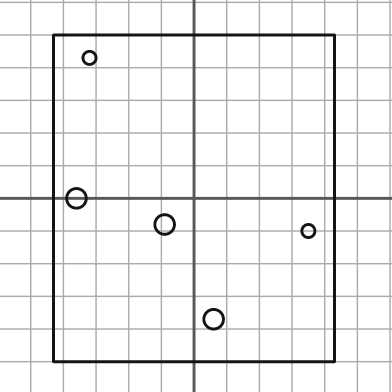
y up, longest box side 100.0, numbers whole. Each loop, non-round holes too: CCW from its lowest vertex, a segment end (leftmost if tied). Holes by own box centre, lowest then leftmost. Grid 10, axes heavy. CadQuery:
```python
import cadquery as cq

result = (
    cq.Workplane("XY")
    .moveTo(-43.0, -50.0)
    .lineTo(43.0, -50.0)
    .lineTo(43.0, 50.0)
    .lineTo(-43.0, 50.0)
    .close()
    .moveTo(6.0, -37.0)
    .circle(3.0)
    .moveTo(35.0, -10.0)
    .circle(2.0)
    .moveTo(-9.0, -8.0)
    .circle(3.0)
    .moveTo(-36.0, 0.0)
    .circle(3.0)
    .moveTo(-32.0, 43.0)
    .circle(2.0)
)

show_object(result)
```